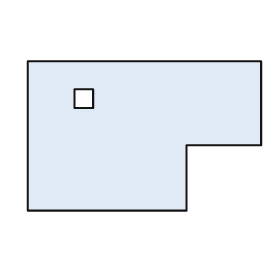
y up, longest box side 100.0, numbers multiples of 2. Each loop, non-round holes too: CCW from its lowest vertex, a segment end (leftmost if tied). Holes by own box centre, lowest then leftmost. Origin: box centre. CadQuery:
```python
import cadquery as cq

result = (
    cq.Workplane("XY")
    .moveTo(-50.0, -32.0)
    .lineTo(18.0, -32.0)
    .lineTo(18.0, -4.0)
    .lineTo(50.0, -4.0)
    .lineTo(50.0, 32.0)
    .lineTo(-50.0, 32.0)
    .close()
    .moveTo(-30.0, 12.0)
    .lineTo(-22.0, 12.0)
    .lineTo(-22.0, 20.0)
    .lineTo(-30.0, 20.0)
    .close()
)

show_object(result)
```